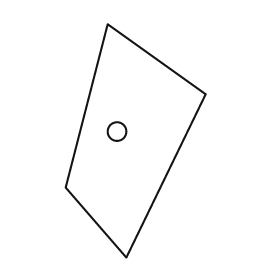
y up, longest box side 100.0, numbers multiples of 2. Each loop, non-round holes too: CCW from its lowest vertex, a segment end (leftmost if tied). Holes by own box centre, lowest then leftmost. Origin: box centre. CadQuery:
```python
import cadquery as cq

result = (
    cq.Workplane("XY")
    .moveTo(-4.0, -50.0)
    .lineTo(30.0, 20.0)
    .lineTo(-12.0, 50.0)
    .lineTo(-30.0, -20.0)
    .close()
    .moveTo(-8.0, 4.0)
    .circle(4.0)
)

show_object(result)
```